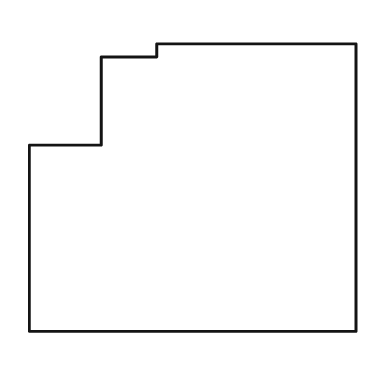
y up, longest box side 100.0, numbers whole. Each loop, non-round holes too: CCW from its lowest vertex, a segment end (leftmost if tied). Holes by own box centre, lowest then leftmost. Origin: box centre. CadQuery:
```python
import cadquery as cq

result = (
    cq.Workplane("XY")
    .moveTo(-50.0, -44.0)
    .lineTo(50.0, -44.0)
    .lineTo(50.0, 44.0)
    .lineTo(-11.0, 44.0)
    .lineTo(-11.0, 40.0)
    .lineTo(-28.0, 40.0)
    .lineTo(-28.0, 13.0)
    .lineTo(-50.0, 13.0)
    .close()
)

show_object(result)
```